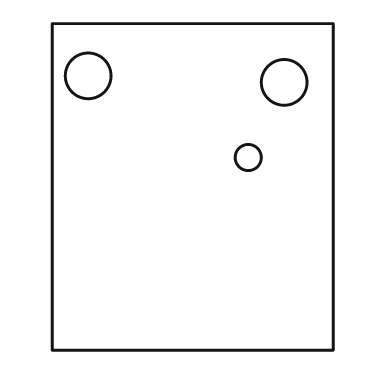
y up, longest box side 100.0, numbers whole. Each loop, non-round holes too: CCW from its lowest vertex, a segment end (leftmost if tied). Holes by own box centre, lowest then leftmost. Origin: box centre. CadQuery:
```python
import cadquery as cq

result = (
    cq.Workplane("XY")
    .moveTo(-43.0, -50.0)
    .lineTo(43.0, -50.0)
    .lineTo(43.0, 50.0)
    .lineTo(-43.0, 50.0)
    .close()
    .moveTo(17.0, 9.0)
    .circle(4.0)
    .moveTo(28.0, 32.0)
    .circle(7.0)
    .moveTo(-32.0, 34.0)
    .circle(7.0)
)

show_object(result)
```